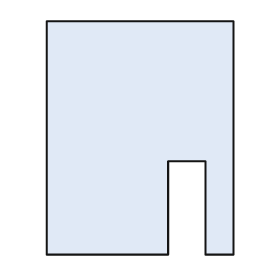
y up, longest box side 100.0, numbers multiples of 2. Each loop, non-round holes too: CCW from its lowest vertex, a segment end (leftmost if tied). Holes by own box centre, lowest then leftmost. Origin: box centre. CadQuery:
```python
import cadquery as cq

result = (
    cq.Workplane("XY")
    .moveTo(-40.0, -50.0)
    .lineTo(12.0, -50.0)
    .lineTo(12.0, -10.0)
    .lineTo(28.0, -10.0)
    .lineTo(28.0, -50.0)
    .lineTo(40.0, -50.0)
    .lineTo(40.0, 50.0)
    .lineTo(-40.0, 50.0)
    .close()
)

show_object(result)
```